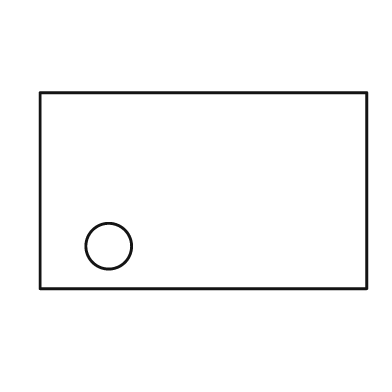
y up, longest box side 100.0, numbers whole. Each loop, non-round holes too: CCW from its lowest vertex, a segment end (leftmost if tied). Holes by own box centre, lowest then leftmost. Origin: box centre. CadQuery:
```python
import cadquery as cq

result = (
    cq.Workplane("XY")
    .moveTo(-50.0, -30.0)
    .lineTo(50.0, -30.0)
    .lineTo(50.0, 30.0)
    .lineTo(-50.0, 30.0)
    .close()
    .moveTo(-29.0, -17.0)
    .circle(7.0)
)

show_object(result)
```